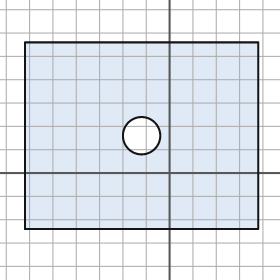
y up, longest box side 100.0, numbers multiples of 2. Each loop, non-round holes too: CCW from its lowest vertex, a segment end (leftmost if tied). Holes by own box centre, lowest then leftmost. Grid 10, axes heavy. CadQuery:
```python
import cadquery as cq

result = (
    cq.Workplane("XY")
    .moveTo(-62.0, -24.0)
    .lineTo(38.0, -24.0)
    .lineTo(38.0, 56.0)
    .lineTo(-62.0, 56.0)
    .close()
    .moveTo(-12.0, 16.0)
    .circle(8.0)
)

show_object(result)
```